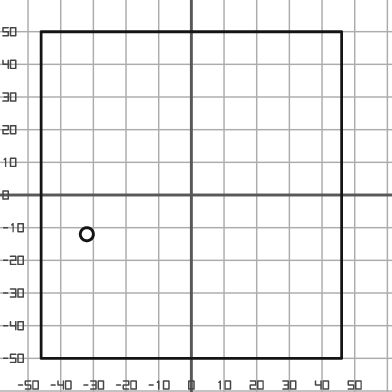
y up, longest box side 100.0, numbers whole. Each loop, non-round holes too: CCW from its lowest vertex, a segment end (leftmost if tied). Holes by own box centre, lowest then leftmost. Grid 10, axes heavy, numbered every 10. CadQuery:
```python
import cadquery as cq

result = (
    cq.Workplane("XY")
    .moveTo(-46.0, -50.0)
    .lineTo(46.0, -50.0)
    .lineTo(46.0, 50.0)
    .lineTo(-46.0, 50.0)
    .close()
    .moveTo(-32.0, -12.0)
    .circle(2.0)
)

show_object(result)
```